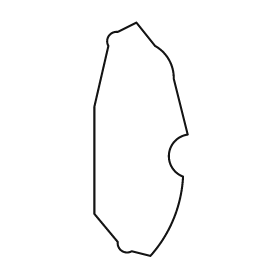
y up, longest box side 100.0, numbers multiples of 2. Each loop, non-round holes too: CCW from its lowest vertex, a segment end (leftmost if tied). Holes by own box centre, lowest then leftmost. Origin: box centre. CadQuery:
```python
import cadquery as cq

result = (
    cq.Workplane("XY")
    .moveTo(4.0, -50.0)
    .threePointArc((14.0, -34.0), (18.0, -16.0))
    .threePointArc((12.0, -6.0), (20.0, 2.0))
    .lineTo(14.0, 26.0)
    .threePointArc((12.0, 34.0), (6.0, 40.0))
    .lineTo(-2.0, 50.0)
    .lineTo(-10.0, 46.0)
    .threePointArc((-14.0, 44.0), (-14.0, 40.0))
    .lineTo(-20.0, 14.0)
    .lineTo(-20.0, -32.0)
    .lineTo(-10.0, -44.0)
    .threePointArc((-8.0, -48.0), (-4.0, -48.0))
    .close()
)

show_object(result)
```